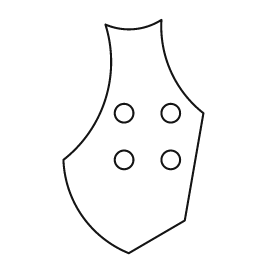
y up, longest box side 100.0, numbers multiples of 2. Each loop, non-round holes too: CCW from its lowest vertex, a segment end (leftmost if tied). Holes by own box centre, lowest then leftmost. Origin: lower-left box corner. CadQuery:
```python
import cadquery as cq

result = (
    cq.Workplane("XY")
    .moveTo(28.0, 0.0)
    .lineTo(52.0, 14.0)
    .lineTo(60.0, 60.0)
    .threePointArc((46.0, 78.0), (42.0, 100.0))
    .threePointArc((30.0, 96.0), (18.0, 98.0))
    .threePointArc((18.0, 66.0), (0.0, 40.0))
    .threePointArc((8.0, 16.0), (28.0, 0.0))
    .close()
    .moveTo(26.0, 40.0)
    .circle(4.0)
    .moveTo(46.0, 40.0)
    .circle(4.0)
    .moveTo(26.0, 60.0)
    .circle(4.0)
    .moveTo(46.0, 60.0)
    .circle(4.0)
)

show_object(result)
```